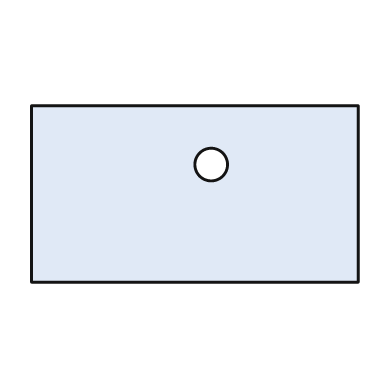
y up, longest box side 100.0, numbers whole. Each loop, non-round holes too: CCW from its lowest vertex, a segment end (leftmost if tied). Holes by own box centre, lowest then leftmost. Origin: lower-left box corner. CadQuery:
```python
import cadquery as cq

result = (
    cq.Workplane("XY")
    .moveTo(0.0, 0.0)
    .lineTo(100.0, 0.0)
    .lineTo(100.0, 54.0)
    .lineTo(0.0, 54.0)
    .close()
    .moveTo(55.0, 36.0)
    .circle(5.0)
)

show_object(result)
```